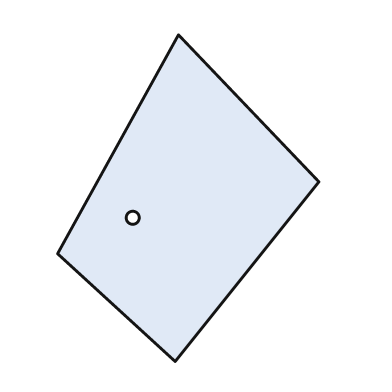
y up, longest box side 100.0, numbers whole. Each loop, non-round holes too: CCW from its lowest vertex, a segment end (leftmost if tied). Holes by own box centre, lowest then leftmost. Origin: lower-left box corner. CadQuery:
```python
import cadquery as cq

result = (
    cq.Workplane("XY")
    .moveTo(36.0, 0.0)
    .lineTo(80.0, 55.0)
    .lineTo(37.0, 100.0)
    .lineTo(0.0, 33.0)
    .close()
    .moveTo(23.0, 44.0)
    .circle(2.0)
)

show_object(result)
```